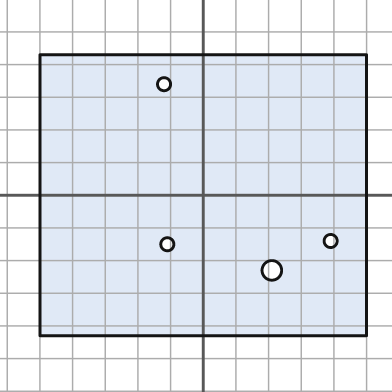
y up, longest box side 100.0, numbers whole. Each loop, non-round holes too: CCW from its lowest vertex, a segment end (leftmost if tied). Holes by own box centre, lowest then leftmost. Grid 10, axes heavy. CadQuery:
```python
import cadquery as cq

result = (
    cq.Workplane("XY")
    .moveTo(-50.0, -43.0)
    .lineTo(50.0, -43.0)
    .lineTo(50.0, 43.0)
    .lineTo(-50.0, 43.0)
    .close()
    .moveTo(21.0, -23.0)
    .circle(3.0)
    .moveTo(-11.0, -15.0)
    .circle(2.0)
    .moveTo(39.0, -14.0)
    .circle(2.0)
    .moveTo(-12.0, 34.0)
    .circle(2.0)
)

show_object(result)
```